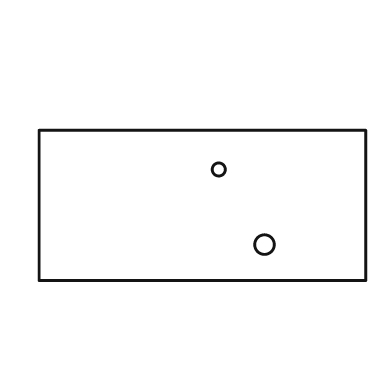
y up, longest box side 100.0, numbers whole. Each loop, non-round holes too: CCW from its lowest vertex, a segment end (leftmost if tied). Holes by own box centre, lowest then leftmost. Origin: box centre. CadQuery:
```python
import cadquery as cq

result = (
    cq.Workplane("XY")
    .moveTo(-50.0, -23.0)
    .lineTo(50.0, -23.0)
    .lineTo(50.0, 23.0)
    .lineTo(-50.0, 23.0)
    .close()
    .moveTo(19.0, -12.0)
    .circle(3.0)
    .moveTo(5.0, 11.0)
    .circle(2.0)
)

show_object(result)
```